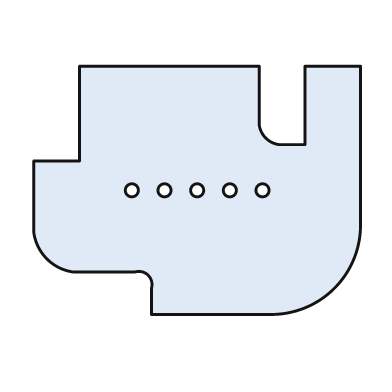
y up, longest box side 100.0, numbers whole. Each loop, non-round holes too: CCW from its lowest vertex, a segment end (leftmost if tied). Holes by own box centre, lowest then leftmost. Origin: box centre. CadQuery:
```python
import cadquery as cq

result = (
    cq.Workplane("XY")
    .moveTo(-14.0, -38.0)
    .lineTo(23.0, -38.0)
    .threePointArc((42.0, -30.0), (50.0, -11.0))
    .lineTo(50.0, 38.0)
    .lineTo(33.0, 38.0)
    .lineTo(33.0, 14.0)
    .lineTo(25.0, 14.0)
    .threePointArc((21.0, 16.0), (19.0, 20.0))
    .lineTo(19.0, 38.0)
    .lineTo(-36.0, 38.0)
    .lineTo(-36.0, 9.0)
    .lineTo(-50.0, 9.0)
    .lineTo(-50.0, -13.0)
    .threePointArc((-46.0, -21.0), (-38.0, -25.0))
    .lineTo(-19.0, -25.0)
    .threePointArc((-15.0, -26.0), (-14.0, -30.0))
    .close()
    .moveTo(-20.0, 0.0)
    .circle(2.0)
    .moveTo(-10.0, 0.0)
    .circle(2.0)
    .moveTo(0.0, 0.0)
    .circle(2.0)
    .moveTo(10.0, 0.0)
    .circle(2.0)
    .moveTo(20.0, 0.0)
    .circle(2.0)
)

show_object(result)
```